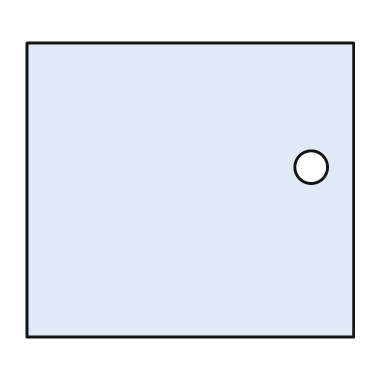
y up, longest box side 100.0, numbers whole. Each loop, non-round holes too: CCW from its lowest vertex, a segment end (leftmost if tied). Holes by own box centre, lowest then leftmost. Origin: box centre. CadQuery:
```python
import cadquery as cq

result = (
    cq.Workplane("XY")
    .moveTo(-50.0, -45.0)
    .lineTo(50.0, -45.0)
    .lineTo(50.0, 45.0)
    .lineTo(-50.0, 45.0)
    .close()
    .moveTo(37.0, 7.0)
    .circle(5.0)
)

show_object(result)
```